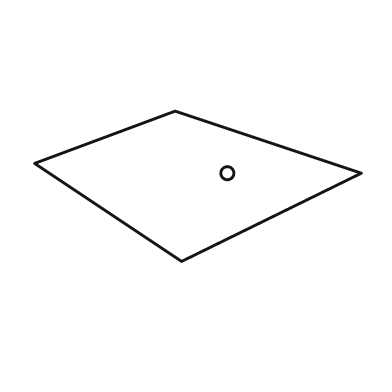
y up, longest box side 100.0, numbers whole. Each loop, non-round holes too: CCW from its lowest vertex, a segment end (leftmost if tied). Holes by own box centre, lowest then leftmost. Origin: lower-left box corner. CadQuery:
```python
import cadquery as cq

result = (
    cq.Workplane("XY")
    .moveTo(45.0, 0.0)
    .lineTo(100.0, 27.0)
    .lineTo(43.0, 46.0)
    .lineTo(0.0, 30.0)
    .close()
    .moveTo(59.0, 27.0)
    .circle(2.0)
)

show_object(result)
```